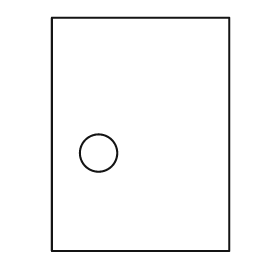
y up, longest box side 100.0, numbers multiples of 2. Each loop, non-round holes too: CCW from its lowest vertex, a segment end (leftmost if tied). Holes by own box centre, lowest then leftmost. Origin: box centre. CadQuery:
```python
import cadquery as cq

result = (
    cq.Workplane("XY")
    .moveTo(-38.0, -50.0)
    .lineTo(38.0, -50.0)
    .lineTo(38.0, 50.0)
    .lineTo(-38.0, 50.0)
    .close()
    .moveTo(-18.0, -8.0)
    .circle(8.0)
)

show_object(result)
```